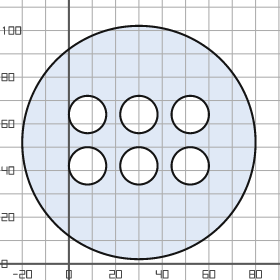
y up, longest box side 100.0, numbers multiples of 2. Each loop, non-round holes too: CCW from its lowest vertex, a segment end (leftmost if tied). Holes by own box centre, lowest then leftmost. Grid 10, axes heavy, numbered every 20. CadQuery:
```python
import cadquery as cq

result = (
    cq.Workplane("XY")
    .moveTo(30.0, 52.0)
    .circle(50.0)
    .moveTo(8.0, 42.0)
    .circle(8.0)
    .moveTo(30.0, 42.0)
    .circle(8.0)
    .moveTo(52.0, 42.0)
    .circle(8.0)
    .moveTo(8.0, 64.0)
    .circle(8.0)
    .moveTo(30.0, 64.0)
    .circle(8.0)
    .moveTo(52.0, 64.0)
    .circle(8.0)
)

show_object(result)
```